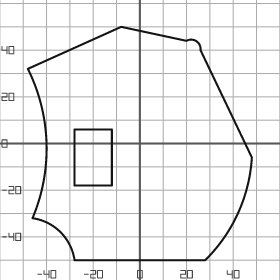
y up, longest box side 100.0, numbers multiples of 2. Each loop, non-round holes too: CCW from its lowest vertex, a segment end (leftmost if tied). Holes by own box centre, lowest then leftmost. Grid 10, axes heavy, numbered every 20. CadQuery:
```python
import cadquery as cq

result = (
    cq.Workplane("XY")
    .moveTo(-28.0, -50.0)
    .lineTo(28.0, -50.0)
    .threePointArc((42.0, -30.0), (48.0, -6.0))
    .lineTo(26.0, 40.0)
    .threePointArc((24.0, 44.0), (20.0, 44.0))
    .lineTo(-8.0, 50.0)
    .lineTo(-48.0, 32.0)
    .threePointArc((-40.0, 0.0), (-46.0, -32.0))
    .threePointArc((-34.0, -38.0), (-28.0, -50.0))
    .close()
    .moveTo(-28.0, -18.0)
    .lineTo(-12.0, -18.0)
    .lineTo(-12.0, 6.0)
    .lineTo(-28.0, 6.0)
    .close()
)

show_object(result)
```